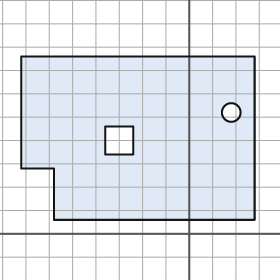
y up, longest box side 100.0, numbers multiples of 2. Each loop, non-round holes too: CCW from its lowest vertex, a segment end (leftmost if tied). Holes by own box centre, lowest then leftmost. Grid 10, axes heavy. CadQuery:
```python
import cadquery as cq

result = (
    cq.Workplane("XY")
    .moveTo(-58.0, 6.0)
    .lineTo(28.0, 6.0)
    .lineTo(28.0, 76.0)
    .lineTo(-72.0, 76.0)
    .lineTo(-72.0, 28.0)
    .lineTo(-58.0, 28.0)
    .close()
    .moveTo(-36.0, 34.0)
    .lineTo(-24.0, 34.0)
    .lineTo(-24.0, 46.0)
    .lineTo(-36.0, 46.0)
    .close()
    .moveTo(18.0, 52.0)
    .circle(4.0)
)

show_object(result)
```